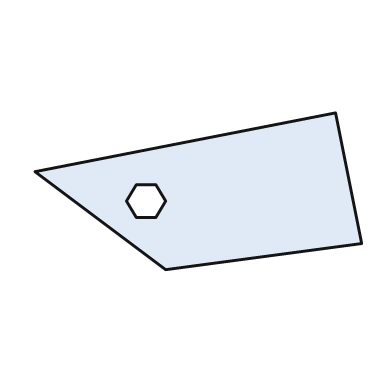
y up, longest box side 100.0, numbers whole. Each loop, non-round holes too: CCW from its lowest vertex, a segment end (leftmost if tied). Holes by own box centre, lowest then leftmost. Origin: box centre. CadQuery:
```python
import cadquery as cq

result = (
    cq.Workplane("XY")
    .moveTo(-10.0, -24.0)
    .lineTo(50.0, -16.0)
    .lineTo(42.0, 24.0)
    .lineTo(-50.0, 6.0)
    .close()
    .moveTo(-19.0, -8.0)
    .lineTo(-13.0, -8.0)
    .lineTo(-10.0, -3.0)
    .lineTo(-13.0, 2.0)
    .lineTo(-19.0, 2.0)
    .lineTo(-22.0, -3.0)
    .close()
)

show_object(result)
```